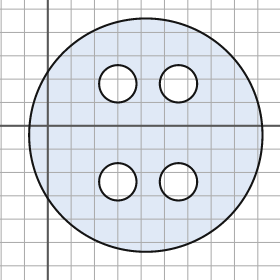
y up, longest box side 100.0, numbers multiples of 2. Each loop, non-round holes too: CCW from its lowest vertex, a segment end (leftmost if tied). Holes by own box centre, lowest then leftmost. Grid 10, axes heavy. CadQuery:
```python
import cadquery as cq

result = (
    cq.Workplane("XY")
    .moveTo(42.0, -4.0)
    .circle(50.0)
    .moveTo(30.0, -24.0)
    .circle(8.0)
    .moveTo(56.0, -24.0)
    .circle(8.0)
    .moveTo(30.0, 18.0)
    .circle(8.0)
    .moveTo(56.0, 18.0)
    .circle(8.0)
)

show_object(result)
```